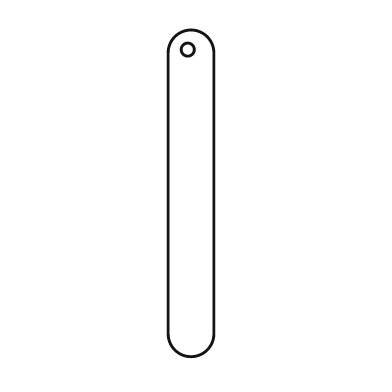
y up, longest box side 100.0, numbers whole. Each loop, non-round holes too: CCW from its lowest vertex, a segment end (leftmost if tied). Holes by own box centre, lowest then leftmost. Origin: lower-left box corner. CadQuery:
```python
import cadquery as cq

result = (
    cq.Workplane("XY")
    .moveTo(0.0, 7.0)
    .threePointArc((7.0, 0.0), (14.0, 7.0))
    .lineTo(14.0, 93.0)
    .threePointArc((7.0, 100.0), (0.0, 93.0))
    .close()
    .moveTo(6.0, 94.0)
    .circle(2.0)
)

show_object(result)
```